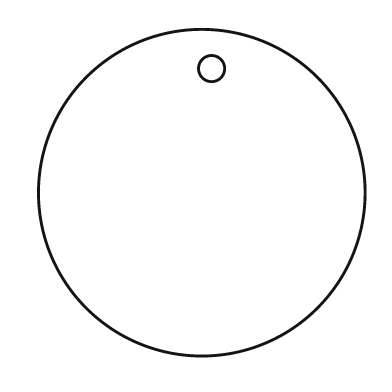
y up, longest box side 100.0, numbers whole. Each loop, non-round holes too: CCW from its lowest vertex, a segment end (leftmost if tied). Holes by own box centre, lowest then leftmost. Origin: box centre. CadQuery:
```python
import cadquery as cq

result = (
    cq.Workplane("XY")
    .moveTo(0.0, 0.0)
    .circle(50.0)
    .moveTo(3.0, 38.0)
    .circle(4.0)
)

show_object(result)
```